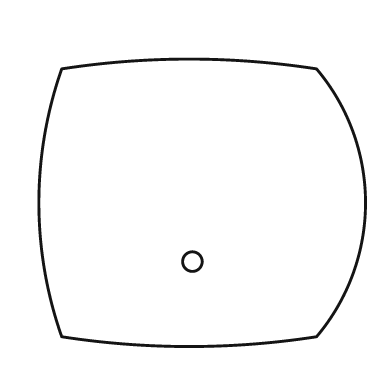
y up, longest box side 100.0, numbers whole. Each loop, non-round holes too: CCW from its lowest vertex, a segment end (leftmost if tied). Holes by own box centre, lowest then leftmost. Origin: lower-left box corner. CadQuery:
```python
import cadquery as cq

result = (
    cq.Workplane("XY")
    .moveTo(7.0, 3.0)
    .threePointArc((46.0, 0.0), (85.0, 3.0))
    .threePointArc((100.0, 44.0), (85.0, 85.0))
    .threePointArc((46.0, 88.0), (7.0, 85.0))
    .threePointArc((0.0, 44.0), (7.0, 3.0))
    .close()
    .moveTo(47.0, 26.0)
    .circle(3.0)
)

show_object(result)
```